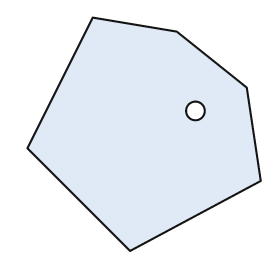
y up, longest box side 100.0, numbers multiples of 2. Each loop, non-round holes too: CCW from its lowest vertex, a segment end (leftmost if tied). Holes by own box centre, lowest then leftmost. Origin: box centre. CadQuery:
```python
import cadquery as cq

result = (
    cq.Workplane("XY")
    .moveTo(-6.0, -50.0)
    .lineTo(50.0, -20.0)
    .lineTo(44.0, 20.0)
    .lineTo(14.0, 44.0)
    .lineTo(-22.0, 50.0)
    .lineTo(-50.0, -6.0)
    .close()
    .moveTo(22.0, 10.0)
    .circle(4.0)
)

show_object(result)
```